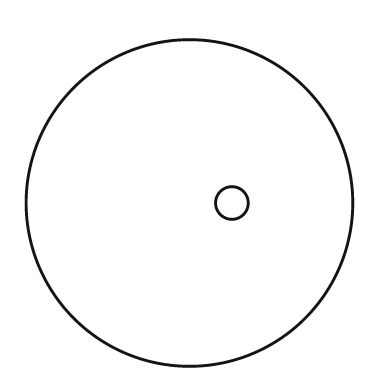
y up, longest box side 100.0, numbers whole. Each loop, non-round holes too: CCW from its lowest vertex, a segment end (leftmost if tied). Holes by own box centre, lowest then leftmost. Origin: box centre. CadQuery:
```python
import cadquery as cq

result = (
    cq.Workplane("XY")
    .moveTo(0.0, 0.0)
    .circle(50.0)
    .moveTo(13.0, 0.0)
    .circle(5.0)
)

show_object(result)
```